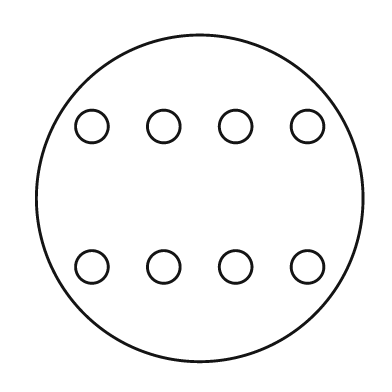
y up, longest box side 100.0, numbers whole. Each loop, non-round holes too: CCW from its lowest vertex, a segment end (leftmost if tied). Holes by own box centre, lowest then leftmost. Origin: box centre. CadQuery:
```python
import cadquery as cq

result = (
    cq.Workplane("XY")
    .moveTo(0.0, 0.0)
    .circle(50.0)
    .moveTo(-33.0, -21.0)
    .circle(5.0)
    .moveTo(-11.0, -21.0)
    .circle(5.0)
    .moveTo(11.0, -21.0)
    .circle(5.0)
    .moveTo(33.0, -21.0)
    .circle(5.0)
    .moveTo(-33.0, 22.0)
    .circle(5.0)
    .moveTo(-11.0, 22.0)
    .circle(5.0)
    .moveTo(11.0, 22.0)
    .circle(5.0)
    .moveTo(33.0, 22.0)
    .circle(5.0)
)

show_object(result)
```